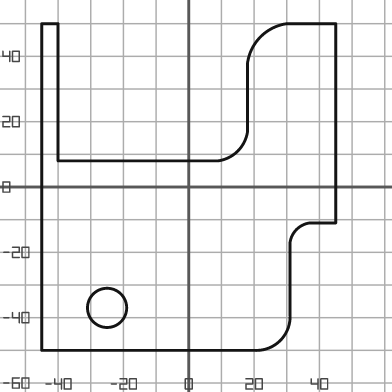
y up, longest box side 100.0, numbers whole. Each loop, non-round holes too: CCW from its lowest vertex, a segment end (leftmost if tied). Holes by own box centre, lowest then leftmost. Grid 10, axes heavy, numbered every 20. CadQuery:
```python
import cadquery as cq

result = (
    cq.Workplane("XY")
    .moveTo(-45.0, -50.0)
    .lineTo(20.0, -50.0)
    .threePointArc((28.0, -47.0), (31.0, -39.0))
    .lineTo(31.0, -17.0)
    .threePointArc((33.0, -13.0), (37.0, -11.0))
    .lineTo(45.0, -11.0)
    .lineTo(45.0, 50.0)
    .lineTo(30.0, 50.0)
    .threePointArc((22.0, 46.0), (18.0, 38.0))
    .lineTo(18.0, 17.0)
    .threePointArc((15.0, 11.0), (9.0, 8.0))
    .lineTo(-40.0, 8.0)
    .lineTo(-40.0, 50.0)
    .lineTo(-45.0, 50.0)
    .close()
    .moveTo(-25.0, -37.0)
    .circle(6.0)
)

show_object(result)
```